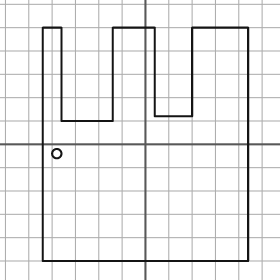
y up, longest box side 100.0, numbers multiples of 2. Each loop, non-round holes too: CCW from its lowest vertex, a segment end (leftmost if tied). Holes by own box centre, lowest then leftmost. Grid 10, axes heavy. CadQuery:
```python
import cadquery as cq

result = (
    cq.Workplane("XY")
    .moveTo(-44.0, -50.0)
    .lineTo(44.0, -50.0)
    .lineTo(44.0, 50.0)
    .lineTo(20.0, 50.0)
    .lineTo(20.0, 12.0)
    .lineTo(4.0, 12.0)
    .lineTo(4.0, 50.0)
    .lineTo(-14.0, 50.0)
    .lineTo(-14.0, 10.0)
    .lineTo(-36.0, 10.0)
    .lineTo(-36.0, 50.0)
    .lineTo(-44.0, 50.0)
    .close()
    .moveTo(-38.0, -4.0)
    .circle(2.0)
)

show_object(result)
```